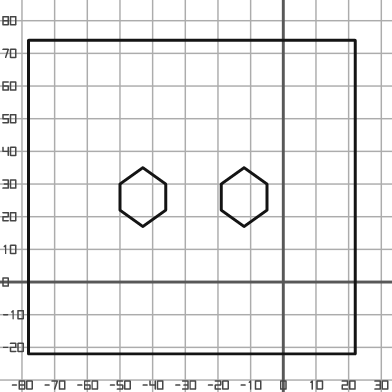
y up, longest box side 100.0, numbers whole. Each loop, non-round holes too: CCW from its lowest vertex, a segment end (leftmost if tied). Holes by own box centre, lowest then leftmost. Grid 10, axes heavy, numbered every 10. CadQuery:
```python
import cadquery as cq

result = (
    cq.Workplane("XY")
    .moveTo(-78.0, -22.0)
    .lineTo(22.0, -22.0)
    .lineTo(22.0, 74.0)
    .lineTo(-78.0, 74.0)
    .close()
    .moveTo(-43.0, 17.0)
    .lineTo(-36.0, 22.0)
    .lineTo(-36.0, 30.0)
    .lineTo(-43.0, 35.0)
    .lineTo(-50.0, 30.0)
    .lineTo(-50.0, 22.0)
    .close()
    .moveTo(-12.0, 17.0)
    .lineTo(-5.0, 22.0)
    .lineTo(-5.0, 30.0)
    .lineTo(-12.0, 35.0)
    .lineTo(-19.0, 30.0)
    .lineTo(-19.0, 22.0)
    .close()
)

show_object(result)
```